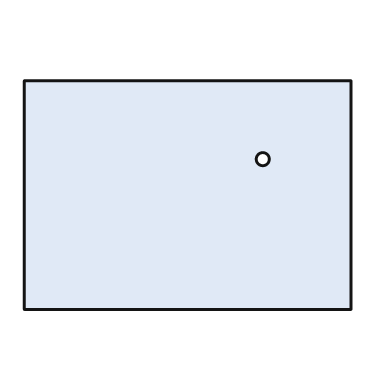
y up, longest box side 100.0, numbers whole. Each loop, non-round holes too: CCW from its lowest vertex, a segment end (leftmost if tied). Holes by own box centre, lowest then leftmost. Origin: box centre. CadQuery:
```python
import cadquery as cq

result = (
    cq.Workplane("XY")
    .moveTo(-50.0, -35.0)
    .lineTo(50.0, -35.0)
    .lineTo(50.0, 35.0)
    .lineTo(-50.0, 35.0)
    .close()
    .moveTo(23.0, 11.0)
    .circle(2.0)
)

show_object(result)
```